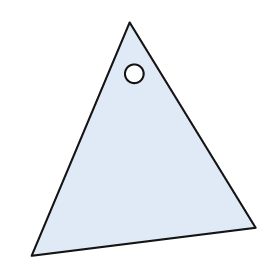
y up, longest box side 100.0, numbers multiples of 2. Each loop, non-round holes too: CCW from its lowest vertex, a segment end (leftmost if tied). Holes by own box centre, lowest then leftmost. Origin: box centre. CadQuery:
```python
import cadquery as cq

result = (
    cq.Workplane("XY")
    .moveTo(-48.0, -50.0)
    .lineTo(48.0, -38.0)
    .lineTo(-6.0, 50.0)
    .close()
    .moveTo(-4.0, 28.0)
    .circle(4.0)
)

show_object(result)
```